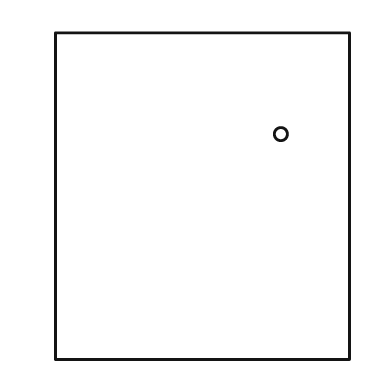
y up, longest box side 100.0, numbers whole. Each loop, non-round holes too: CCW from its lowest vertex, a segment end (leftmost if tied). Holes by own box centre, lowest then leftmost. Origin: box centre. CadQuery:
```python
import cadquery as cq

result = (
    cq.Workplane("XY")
    .moveTo(-45.0, -50.0)
    .lineTo(45.0, -50.0)
    .lineTo(45.0, 50.0)
    .lineTo(-45.0, 50.0)
    .close()
    .moveTo(24.0, 19.0)
    .circle(2.0)
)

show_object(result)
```